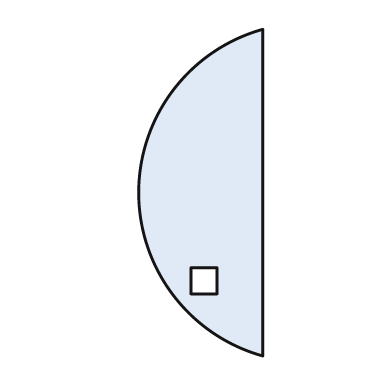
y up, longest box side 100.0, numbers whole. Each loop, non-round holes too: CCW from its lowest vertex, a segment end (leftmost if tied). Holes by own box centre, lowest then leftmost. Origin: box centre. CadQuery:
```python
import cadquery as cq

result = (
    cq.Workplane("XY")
    .moveTo(19.0, -50.0)
    .lineTo(19.0, 50.0)
    .threePointArc((-19.0, 0.0), (19.0, -50.0))
    .close()
    .moveTo(-3.0, -31.0)
    .lineTo(5.0, -31.0)
    .lineTo(5.0, -23.0)
    .lineTo(-3.0, -23.0)
    .close()
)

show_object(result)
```